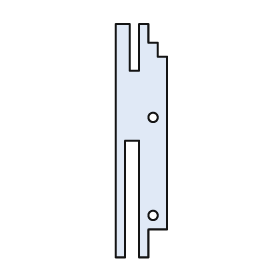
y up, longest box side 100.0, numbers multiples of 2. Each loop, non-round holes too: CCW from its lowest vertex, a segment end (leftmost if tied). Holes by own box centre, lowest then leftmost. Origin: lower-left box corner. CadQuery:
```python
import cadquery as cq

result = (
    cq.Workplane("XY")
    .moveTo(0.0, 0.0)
    .lineTo(4.0, 0.0)
    .lineTo(4.0, 50.0)
    .lineTo(10.0, 50.0)
    .lineTo(10.0, 0.0)
    .lineTo(14.0, 0.0)
    .lineTo(14.0, 12.0)
    .lineTo(22.0, 12.0)
    .lineTo(22.0, 86.0)
    .lineTo(18.0, 86.0)
    .lineTo(18.0, 92.0)
    .lineTo(14.0, 92.0)
    .lineTo(14.0, 100.0)
    .lineTo(10.0, 100.0)
    .lineTo(10.0, 80.0)
    .lineTo(6.0, 80.0)
    .lineTo(6.0, 100.0)
    .lineTo(0.0, 100.0)
    .close()
    .moveTo(16.0, 18.0)
    .circle(2.0)
    .moveTo(16.0, 60.0)
    .circle(2.0)
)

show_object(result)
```